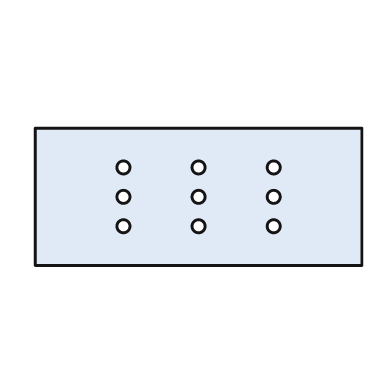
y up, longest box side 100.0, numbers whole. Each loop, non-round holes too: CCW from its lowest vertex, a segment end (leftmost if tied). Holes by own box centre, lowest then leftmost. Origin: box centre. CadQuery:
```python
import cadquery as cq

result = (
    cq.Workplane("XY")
    .moveTo(-50.0, -21.0)
    .lineTo(50.0, -21.0)
    .lineTo(50.0, 21.0)
    .lineTo(-50.0, 21.0)
    .close()
    .moveTo(-23.0, -9.0)
    .circle(2.0)
    .moveTo(0.0, -9.0)
    .circle(2.0)
    .moveTo(23.0, -9.0)
    .circle(2.0)
    .moveTo(-23.0, 0.0)
    .circle(2.0)
    .moveTo(0.0, 0.0)
    .circle(2.0)
    .moveTo(23.0, 0.0)
    .circle(2.0)
    .moveTo(-23.0, 9.0)
    .circle(2.0)
    .moveTo(0.0, 9.0)
    .circle(2.0)
    .moveTo(23.0, 9.0)
    .circle(2.0)
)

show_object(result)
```